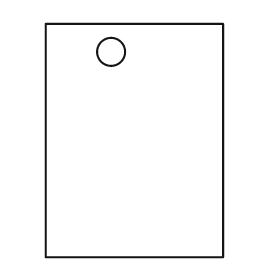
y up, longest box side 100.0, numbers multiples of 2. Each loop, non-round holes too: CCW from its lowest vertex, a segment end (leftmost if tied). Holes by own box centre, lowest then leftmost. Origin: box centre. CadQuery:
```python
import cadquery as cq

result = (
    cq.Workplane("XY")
    .moveTo(-38.0, -50.0)
    .lineTo(38.0, -50.0)
    .lineTo(38.0, 50.0)
    .lineTo(-38.0, 50.0)
    .close()
    .moveTo(-10.0, 38.0)
    .circle(6.0)
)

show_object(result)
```